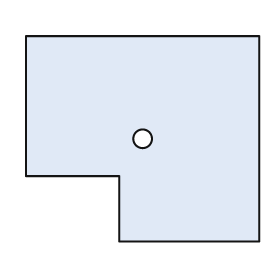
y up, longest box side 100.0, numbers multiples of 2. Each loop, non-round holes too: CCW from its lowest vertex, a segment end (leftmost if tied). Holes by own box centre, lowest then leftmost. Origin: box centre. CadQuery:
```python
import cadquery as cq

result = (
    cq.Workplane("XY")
    .moveTo(-10.0, -44.0)
    .lineTo(50.0, -44.0)
    .lineTo(50.0, 44.0)
    .lineTo(-50.0, 44.0)
    .lineTo(-50.0, -16.0)
    .lineTo(-10.0, -16.0)
    .close()
    .moveTo(0.0, 0.0)
    .circle(4.0)
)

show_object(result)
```